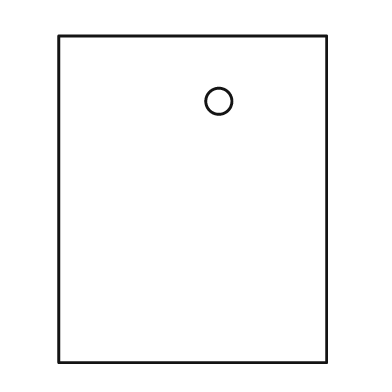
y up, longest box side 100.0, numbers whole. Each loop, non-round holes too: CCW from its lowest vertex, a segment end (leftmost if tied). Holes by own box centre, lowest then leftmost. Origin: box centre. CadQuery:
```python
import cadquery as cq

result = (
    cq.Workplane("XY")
    .moveTo(-41.0, -50.0)
    .lineTo(41.0, -50.0)
    .lineTo(41.0, 50.0)
    .lineTo(-41.0, 50.0)
    .close()
    .moveTo(8.0, 30.0)
    .circle(4.0)
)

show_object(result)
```